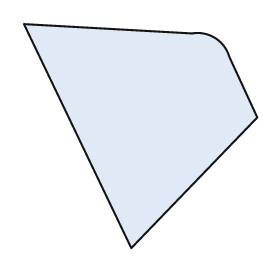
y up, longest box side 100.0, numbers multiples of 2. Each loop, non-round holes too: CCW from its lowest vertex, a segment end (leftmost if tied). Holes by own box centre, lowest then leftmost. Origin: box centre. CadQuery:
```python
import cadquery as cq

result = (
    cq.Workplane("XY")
    .moveTo(-4.0, -48.0)
    .lineTo(50.0, 8.0)
    .lineTo(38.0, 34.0)
    .threePointArc((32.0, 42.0), (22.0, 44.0))
    .lineTo(-50.0, 48.0)
    .close()
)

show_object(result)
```